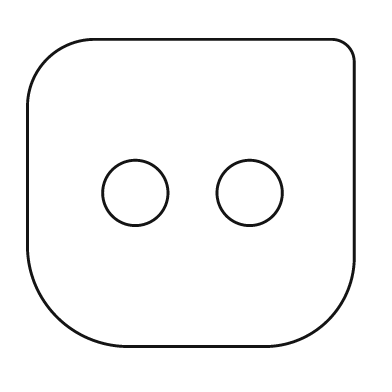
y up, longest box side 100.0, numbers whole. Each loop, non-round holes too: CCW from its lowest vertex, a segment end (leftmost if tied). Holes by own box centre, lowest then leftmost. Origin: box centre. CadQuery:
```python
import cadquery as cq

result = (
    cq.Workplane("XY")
    .moveTo(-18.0, -47.0)
    .lineTo(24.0, -47.0)
    .threePointArc((42.0, -39.0), (50.0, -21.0))
    .lineTo(50.0, 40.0)
    .threePointArc((48.0, 45.0), (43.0, 47.0))
    .lineTo(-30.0, 47.0)
    .threePointArc((-44.0, 41.0), (-50.0, 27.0))
    .lineTo(-50.0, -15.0)
    .threePointArc((-41.0, -38.0), (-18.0, -47.0))
    .close()
    .moveTo(-17.0, 0.0)
    .circle(10.0)
    .moveTo(18.0, 0.0)
    .circle(10.0)
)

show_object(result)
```